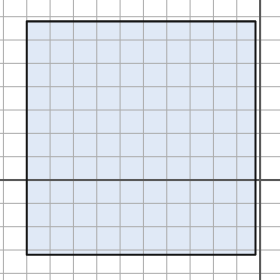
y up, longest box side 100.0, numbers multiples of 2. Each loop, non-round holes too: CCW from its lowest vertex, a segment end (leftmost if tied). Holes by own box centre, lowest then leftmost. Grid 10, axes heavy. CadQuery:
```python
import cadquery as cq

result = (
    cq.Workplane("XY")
    .moveTo(-100.0, -32.0)
    .lineTo(-2.0, -32.0)
    .lineTo(-2.0, 68.0)
    .lineTo(-100.0, 68.0)
    .close()
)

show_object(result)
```